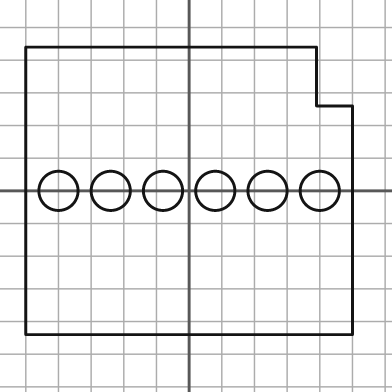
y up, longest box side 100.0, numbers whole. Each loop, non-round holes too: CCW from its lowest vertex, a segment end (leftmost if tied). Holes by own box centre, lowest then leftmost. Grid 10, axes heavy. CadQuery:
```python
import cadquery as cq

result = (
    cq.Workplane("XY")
    .moveTo(-50.0, -44.0)
    .lineTo(50.0, -44.0)
    .lineTo(50.0, 26.0)
    .lineTo(39.0, 26.0)
    .lineTo(39.0, 44.0)
    .lineTo(-50.0, 44.0)
    .close()
    .moveTo(-40.0, 0.0)
    .circle(6.0)
    .moveTo(-24.0, 0.0)
    .circle(6.0)
    .moveTo(-8.0, 0.0)
    .circle(6.0)
    .moveTo(8.0, 0.0)
    .circle(6.0)
    .moveTo(24.0, 0.0)
    .circle(6.0)
    .moveTo(40.0, 0.0)
    .circle(6.0)
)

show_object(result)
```